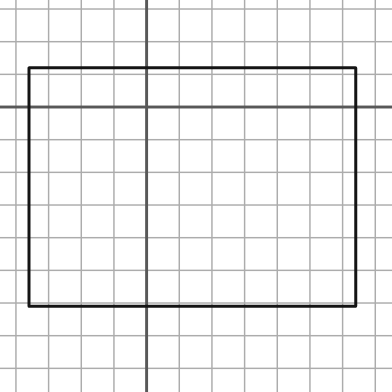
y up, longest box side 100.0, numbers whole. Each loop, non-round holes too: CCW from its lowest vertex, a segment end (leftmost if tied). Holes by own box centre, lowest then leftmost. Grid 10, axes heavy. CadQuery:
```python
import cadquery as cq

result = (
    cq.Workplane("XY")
    .moveTo(-36.0, -61.0)
    .lineTo(64.0, -61.0)
    .lineTo(64.0, 12.0)
    .lineTo(-36.0, 12.0)
    .close()
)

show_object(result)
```